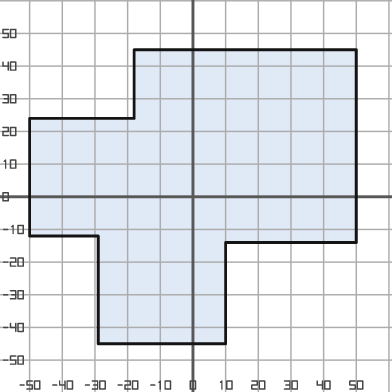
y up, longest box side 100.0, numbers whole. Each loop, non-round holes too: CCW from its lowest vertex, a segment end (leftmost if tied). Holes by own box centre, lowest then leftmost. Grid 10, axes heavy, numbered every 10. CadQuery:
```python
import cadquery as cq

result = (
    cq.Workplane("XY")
    .moveTo(-29.0, -45.0)
    .lineTo(10.0, -45.0)
    .lineTo(10.0, -14.0)
    .lineTo(50.0, -14.0)
    .lineTo(50.0, 45.0)
    .lineTo(-18.0, 45.0)
    .lineTo(-18.0, 24.0)
    .lineTo(-50.0, 24.0)
    .lineTo(-50.0, -12.0)
    .lineTo(-29.0, -12.0)
    .close()
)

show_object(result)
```